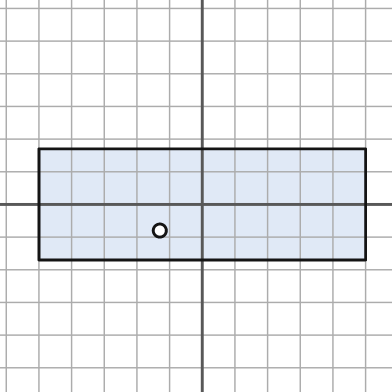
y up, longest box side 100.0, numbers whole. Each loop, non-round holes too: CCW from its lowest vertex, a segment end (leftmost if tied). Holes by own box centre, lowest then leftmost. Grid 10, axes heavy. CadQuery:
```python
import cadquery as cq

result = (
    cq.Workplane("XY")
    .moveTo(-50.0, -17.0)
    .lineTo(50.0, -17.0)
    .lineTo(50.0, 17.0)
    .lineTo(-50.0, 17.0)
    .close()
    .moveTo(-13.0, -8.0)
    .circle(2.0)
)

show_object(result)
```